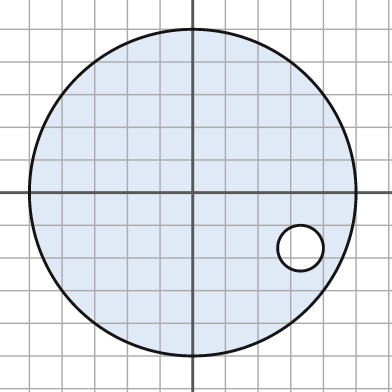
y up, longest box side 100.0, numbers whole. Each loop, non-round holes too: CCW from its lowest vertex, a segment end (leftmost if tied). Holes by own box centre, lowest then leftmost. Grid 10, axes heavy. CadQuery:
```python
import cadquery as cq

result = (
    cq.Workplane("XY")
    .moveTo(0.0, 0.0)
    .circle(50.0)
    .moveTo(33.0, -17.0)
    .circle(7.0)
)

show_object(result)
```